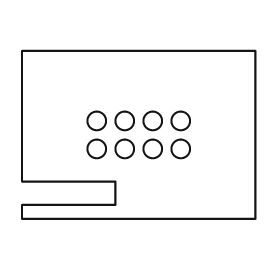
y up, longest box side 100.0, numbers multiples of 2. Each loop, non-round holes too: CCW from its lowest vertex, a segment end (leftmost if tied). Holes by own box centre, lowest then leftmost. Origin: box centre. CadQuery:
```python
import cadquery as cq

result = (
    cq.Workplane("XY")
    .moveTo(-50.0, -36.0)
    .lineTo(50.0, -36.0)
    .lineTo(50.0, 36.0)
    .lineTo(-50.0, 36.0)
    .lineTo(-50.0, -20.0)
    .lineTo(-10.0, -20.0)
    .lineTo(-10.0, -30.0)
    .lineTo(-50.0, -30.0)
    .close()
    .moveTo(-18.0, -6.0)
    .circle(4.0)
    .moveTo(-6.0, -6.0)
    .circle(4.0)
    .moveTo(6.0, -6.0)
    .circle(4.0)
    .moveTo(18.0, -6.0)
    .circle(4.0)
    .moveTo(-18.0, 6.0)
    .circle(4.0)
    .moveTo(-6.0, 6.0)
    .circle(4.0)
    .moveTo(6.0, 6.0)
    .circle(4.0)
    .moveTo(18.0, 6.0)
    .circle(4.0)
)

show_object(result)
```